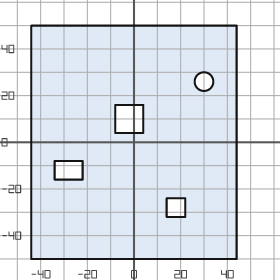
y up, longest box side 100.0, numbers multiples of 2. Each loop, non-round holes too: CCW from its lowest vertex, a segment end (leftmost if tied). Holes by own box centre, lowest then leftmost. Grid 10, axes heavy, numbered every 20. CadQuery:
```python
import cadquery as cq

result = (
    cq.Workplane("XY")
    .moveTo(-44.0, -50.0)
    .lineTo(44.0, -50.0)
    .lineTo(44.0, 50.0)
    .lineTo(-44.0, 50.0)
    .close()
    .moveTo(14.0, -32.0)
    .lineTo(22.0, -32.0)
    .lineTo(22.0, -24.0)
    .lineTo(14.0, -24.0)
    .close()
    .moveTo(-34.0, -16.0)
    .lineTo(-22.0, -16.0)
    .lineTo(-22.0, -8.0)
    .lineTo(-34.0, -8.0)
    .close()
    .moveTo(-8.0, 4.0)
    .lineTo(4.0, 4.0)
    .lineTo(4.0, 16.0)
    .lineTo(-8.0, 16.0)
    .close()
    .moveTo(30.0, 26.0)
    .circle(4.0)
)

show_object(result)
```